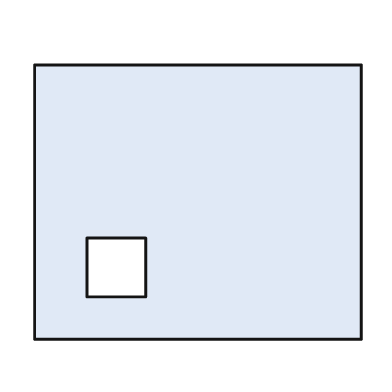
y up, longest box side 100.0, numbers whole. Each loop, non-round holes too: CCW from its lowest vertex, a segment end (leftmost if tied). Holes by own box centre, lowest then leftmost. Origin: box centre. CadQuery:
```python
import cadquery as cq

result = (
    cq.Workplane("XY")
    .moveTo(-50.0, -42.0)
    .lineTo(50.0, -42.0)
    .lineTo(50.0, 42.0)
    .lineTo(-50.0, 42.0)
    .close()
    .moveTo(-34.0, -29.0)
    .lineTo(-16.0, -29.0)
    .lineTo(-16.0, -11.0)
    .lineTo(-34.0, -11.0)
    .close()
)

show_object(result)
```